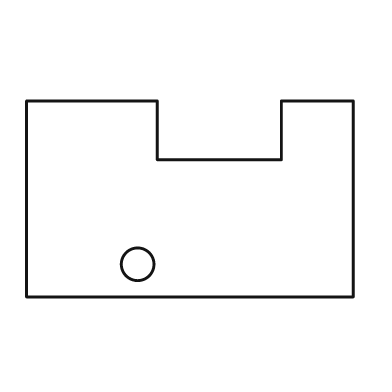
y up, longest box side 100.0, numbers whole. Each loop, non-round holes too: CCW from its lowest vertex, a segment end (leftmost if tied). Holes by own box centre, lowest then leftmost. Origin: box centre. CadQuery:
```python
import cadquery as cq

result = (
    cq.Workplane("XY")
    .moveTo(-50.0, -30.0)
    .lineTo(50.0, -30.0)
    .lineTo(50.0, 30.0)
    .lineTo(28.0, 30.0)
    .lineTo(28.0, 12.0)
    .lineTo(-10.0, 12.0)
    .lineTo(-10.0, 30.0)
    .lineTo(-50.0, 30.0)
    .close()
    .moveTo(-16.0, -20.0)
    .circle(5.0)
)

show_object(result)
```